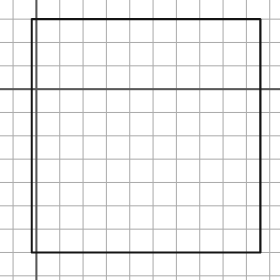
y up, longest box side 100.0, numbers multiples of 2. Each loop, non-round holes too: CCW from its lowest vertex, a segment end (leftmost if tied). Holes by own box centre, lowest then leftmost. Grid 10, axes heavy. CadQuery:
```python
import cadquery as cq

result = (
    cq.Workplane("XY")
    .moveTo(-2.0, -70.0)
    .lineTo(96.0, -70.0)
    .lineTo(96.0, 30.0)
    .lineTo(-2.0, 30.0)
    .close()
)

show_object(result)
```